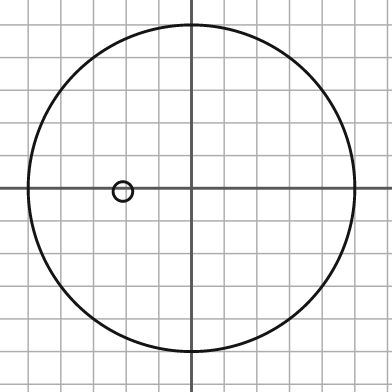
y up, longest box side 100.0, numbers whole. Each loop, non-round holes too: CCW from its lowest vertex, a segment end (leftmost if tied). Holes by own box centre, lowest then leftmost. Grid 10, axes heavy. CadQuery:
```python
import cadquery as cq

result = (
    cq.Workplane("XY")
    .moveTo(0.0, 0.0)
    .circle(50.0)
    .moveTo(-21.0, -1.0)
    .circle(3.0)
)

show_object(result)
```